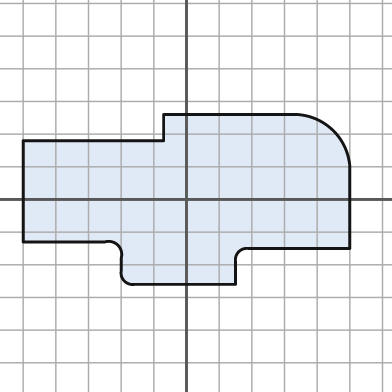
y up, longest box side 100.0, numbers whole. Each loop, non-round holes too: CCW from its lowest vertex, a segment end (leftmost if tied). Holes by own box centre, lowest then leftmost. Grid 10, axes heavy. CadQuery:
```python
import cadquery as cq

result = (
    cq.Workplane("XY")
    .moveTo(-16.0, -26.0)
    .lineTo(15.0, -26.0)
    .lineTo(15.0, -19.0)
    .threePointArc((16.0, -16.0), (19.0, -15.0))
    .lineTo(50.0, -15.0)
    .lineTo(50.0, 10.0)
    .threePointArc((45.0, 21.0), (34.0, 26.0))
    .lineTo(-7.0, 26.0)
    .lineTo(-7.0, 18.0)
    .lineTo(-50.0, 18.0)
    .lineTo(-50.0, -13.0)
    .lineTo(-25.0, -13.0)
    .threePointArc((-21.0, -14.0), (-20.0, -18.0))
    .lineTo(-20.0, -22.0)
    .threePointArc((-19.0, -25.0), (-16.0, -26.0))
    .close()
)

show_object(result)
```